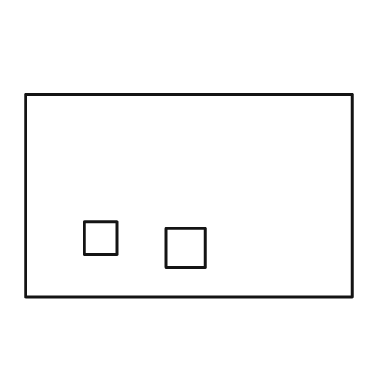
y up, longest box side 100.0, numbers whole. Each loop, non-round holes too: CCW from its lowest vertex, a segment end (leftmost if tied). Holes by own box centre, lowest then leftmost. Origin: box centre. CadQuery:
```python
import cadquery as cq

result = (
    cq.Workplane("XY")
    .moveTo(-50.0, -31.0)
    .lineTo(50.0, -31.0)
    .lineTo(50.0, 31.0)
    .lineTo(-50.0, 31.0)
    .close()
    .moveTo(-7.0, -22.0)
    .lineTo(5.0, -22.0)
    .lineTo(5.0, -10.0)
    .lineTo(-7.0, -10.0)
    .close()
    .moveTo(-32.0, -18.0)
    .lineTo(-22.0, -18.0)
    .lineTo(-22.0, -8.0)
    .lineTo(-32.0, -8.0)
    .close()
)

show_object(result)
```